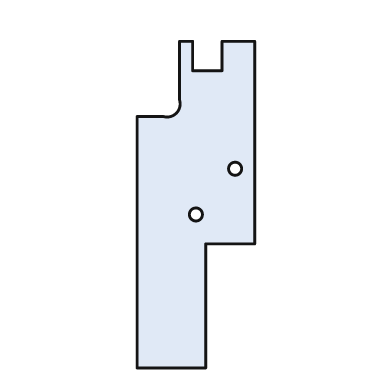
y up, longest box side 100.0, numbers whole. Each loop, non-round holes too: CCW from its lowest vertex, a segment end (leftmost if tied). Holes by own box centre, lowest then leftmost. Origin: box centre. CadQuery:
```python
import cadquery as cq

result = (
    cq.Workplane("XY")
    .moveTo(-18.0, -50.0)
    .lineTo(3.0, -50.0)
    .lineTo(3.0, -12.0)
    .lineTo(18.0, -12.0)
    .lineTo(18.0, 50.0)
    .lineTo(8.0, 50.0)
    .lineTo(8.0, 41.0)
    .lineTo(-1.0, 41.0)
    .lineTo(-1.0, 50.0)
    .lineTo(-5.0, 50.0)
    .lineTo(-5.0, 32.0)
    .threePointArc((-6.0, 28.0), (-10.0, 27.0))
    .lineTo(-18.0, 27.0)
    .close()
    .moveTo(0.0, -3.0)
    .circle(2.0)
    .moveTo(12.0, 11.0)
    .circle(2.0)
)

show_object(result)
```